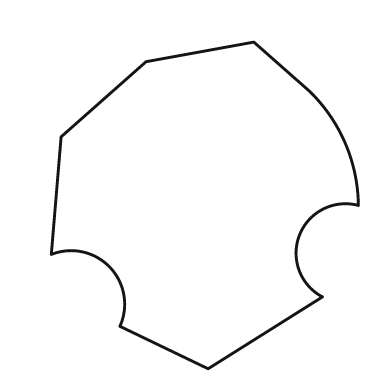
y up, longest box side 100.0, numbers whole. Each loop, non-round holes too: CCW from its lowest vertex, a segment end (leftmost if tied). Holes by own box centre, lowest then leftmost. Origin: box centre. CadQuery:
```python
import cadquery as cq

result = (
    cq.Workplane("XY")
    .moveTo(1.0, -50.0)
    .lineTo(36.0, -28.0)
    .threePointArc((29.0, -9.0), (47.0, 0.0))
    .threePointArc((43.0, 19.0), (32.0, 35.0))
    .lineTo(15.0, 50.0)
    .lineTo(-18.0, 44.0)
    .lineTo(-44.0, 21.0)
    .lineTo(-47.0, -15.0)
    .threePointArc((-29.0, -19.0), (-26.0, -37.0))
    .close()
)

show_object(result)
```